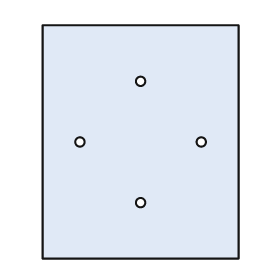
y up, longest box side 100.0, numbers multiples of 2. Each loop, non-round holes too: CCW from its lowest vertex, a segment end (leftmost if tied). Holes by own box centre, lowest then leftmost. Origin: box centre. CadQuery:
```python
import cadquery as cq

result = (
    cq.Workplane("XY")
    .moveTo(-42.0, -50.0)
    .lineTo(42.0, -50.0)
    .lineTo(42.0, 50.0)
    .lineTo(-42.0, 50.0)
    .close()
    .moveTo(0.0, -26.0)
    .circle(2.0)
    .moveTo(-26.0, 0.0)
    .circle(2.0)
    .moveTo(26.0, 0.0)
    .circle(2.0)
    .moveTo(0.0, 26.0)
    .circle(2.0)
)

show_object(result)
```